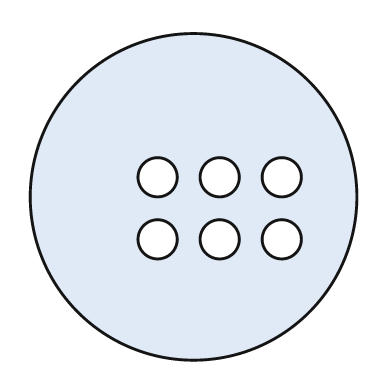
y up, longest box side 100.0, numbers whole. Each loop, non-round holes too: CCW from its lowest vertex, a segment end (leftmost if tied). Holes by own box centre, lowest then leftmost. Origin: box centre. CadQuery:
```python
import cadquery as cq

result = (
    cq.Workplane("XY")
    .moveTo(0.0, 0.0)
    .circle(50.0)
    .moveTo(-11.0, -13.0)
    .circle(6.0)
    .moveTo(8.0, -13.0)
    .circle(6.0)
    .moveTo(27.0, -13.0)
    .circle(6.0)
    .moveTo(-11.0, 6.0)
    .circle(6.0)
    .moveTo(8.0, 6.0)
    .circle(6.0)
    .moveTo(27.0, 6.0)
    .circle(6.0)
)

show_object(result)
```